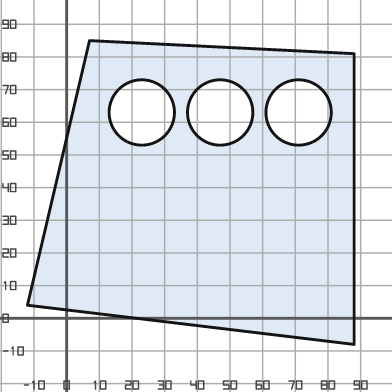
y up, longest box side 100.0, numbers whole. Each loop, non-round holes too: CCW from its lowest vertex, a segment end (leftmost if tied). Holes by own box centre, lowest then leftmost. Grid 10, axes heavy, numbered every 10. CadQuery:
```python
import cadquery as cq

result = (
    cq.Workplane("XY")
    .moveTo(88.0, -8.0)
    .lineTo(88.0, 81.0)
    .lineTo(7.0, 85.0)
    .lineTo(-12.0, 4.0)
    .close()
    .moveTo(23.0, 63.0)
    .circle(10.0)
    .moveTo(47.0, 63.0)
    .circle(10.0)
    .moveTo(71.0, 63.0)
    .circle(10.0)
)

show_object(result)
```